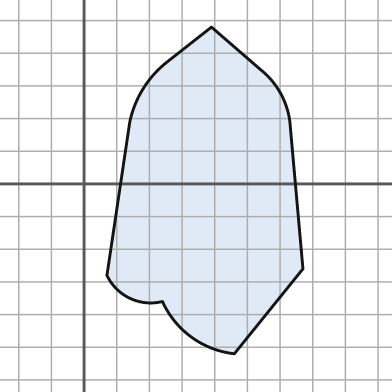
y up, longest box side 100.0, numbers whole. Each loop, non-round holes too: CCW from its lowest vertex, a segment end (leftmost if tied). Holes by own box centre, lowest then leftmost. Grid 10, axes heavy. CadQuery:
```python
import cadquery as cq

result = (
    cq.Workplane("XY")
    .moveTo(46.0, -52.0)
    .lineTo(67.0, -26.0)
    .lineTo(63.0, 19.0)
    .threePointArc((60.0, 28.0), (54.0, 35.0))
    .lineTo(39.0, 48.0)
    .lineTo(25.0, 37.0)
    .threePointArc((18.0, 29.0), (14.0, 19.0))
    .lineTo(7.0, -28.0)
    .threePointArc((14.0, -35.0), (24.0, -36.0))
    .threePointArc((33.0, -47.0), (46.0, -52.0))
    .close()
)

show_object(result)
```